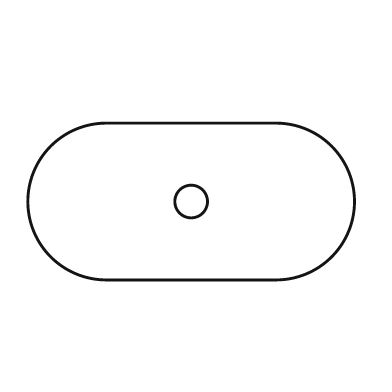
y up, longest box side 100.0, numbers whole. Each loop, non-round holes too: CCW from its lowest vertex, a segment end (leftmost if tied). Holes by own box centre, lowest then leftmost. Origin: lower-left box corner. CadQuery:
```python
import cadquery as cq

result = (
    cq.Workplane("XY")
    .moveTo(24.0, 0.0)
    .lineTo(76.0, 0.0)
    .threePointArc((100.0, 24.0), (76.0, 48.0))
    .lineTo(24.0, 48.0)
    .threePointArc((0.0, 24.0), (24.0, 0.0))
    .close()
    .moveTo(50.0, 24.0)
    .circle(5.0)
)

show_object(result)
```